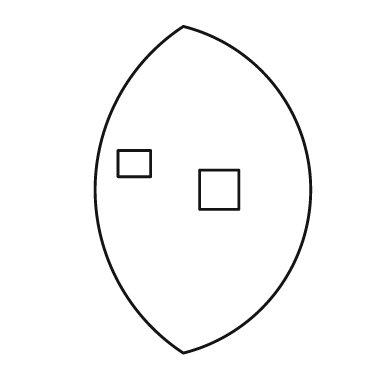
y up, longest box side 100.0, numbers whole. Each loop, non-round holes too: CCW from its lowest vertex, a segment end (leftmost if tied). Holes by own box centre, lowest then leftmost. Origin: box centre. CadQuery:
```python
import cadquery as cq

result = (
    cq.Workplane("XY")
    .moveTo(-6.0, -50.0)
    .threePointArc((33.0, 0.0), (-6.0, 50.0))
    .threePointArc((-33.0, 0.0), (-6.0, -50.0))
    .close()
    .moveTo(-1.0, -6.0)
    .lineTo(11.0, -6.0)
    .lineTo(11.0, 6.0)
    .lineTo(-1.0, 6.0)
    .close()
    .moveTo(-26.0, 4.0)
    .lineTo(-16.0, 4.0)
    .lineTo(-16.0, 12.0)
    .lineTo(-26.0, 12.0)
    .close()
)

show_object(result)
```